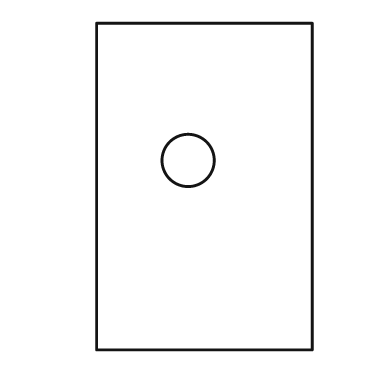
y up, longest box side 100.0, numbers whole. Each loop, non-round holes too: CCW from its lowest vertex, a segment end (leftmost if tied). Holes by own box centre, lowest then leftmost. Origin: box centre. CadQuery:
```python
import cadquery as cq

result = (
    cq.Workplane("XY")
    .moveTo(-33.0, -50.0)
    .lineTo(33.0, -50.0)
    .lineTo(33.0, 50.0)
    .lineTo(-33.0, 50.0)
    .close()
    .moveTo(-5.0, 8.0)
    .circle(8.0)
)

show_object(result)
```